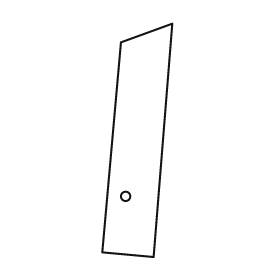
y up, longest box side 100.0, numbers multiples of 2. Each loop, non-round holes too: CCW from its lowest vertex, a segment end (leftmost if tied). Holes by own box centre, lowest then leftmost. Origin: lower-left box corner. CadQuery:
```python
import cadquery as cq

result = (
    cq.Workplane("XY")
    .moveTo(22.0, 0.0)
    .lineTo(30.0, 100.0)
    .lineTo(8.0, 92.0)
    .lineTo(0.0, 2.0)
    .close()
    .moveTo(10.0, 26.0)
    .circle(2.0)
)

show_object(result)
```